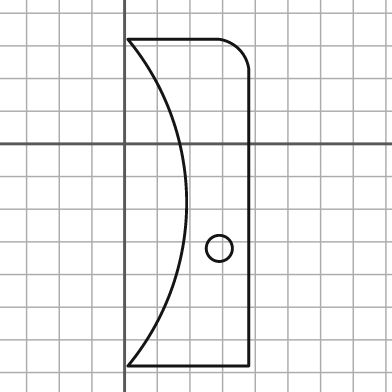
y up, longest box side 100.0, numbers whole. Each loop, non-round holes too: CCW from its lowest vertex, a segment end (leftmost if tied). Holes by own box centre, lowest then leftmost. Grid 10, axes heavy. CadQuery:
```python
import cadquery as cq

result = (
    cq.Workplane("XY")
    .moveTo(1.0, -68.0)
    .lineTo(38.0, -68.0)
    .lineTo(38.0, 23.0)
    .threePointArc((35.0, 29.0), (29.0, 32.0))
    .lineTo(1.0, 32.0)
    .threePointArc((19.0, -18.0), (1.0, -68.0))
    .close()
    .moveTo(29.0, -32.0)
    .circle(4.0)
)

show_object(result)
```